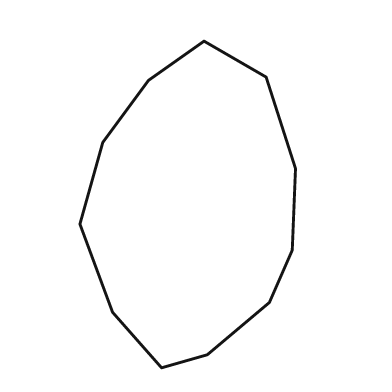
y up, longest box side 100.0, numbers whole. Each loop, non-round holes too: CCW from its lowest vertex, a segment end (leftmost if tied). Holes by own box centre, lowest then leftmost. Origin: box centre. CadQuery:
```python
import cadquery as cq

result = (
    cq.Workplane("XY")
    .moveTo(-8.0, -50.0)
    .lineTo(6.0, -46.0)
    .lineTo(25.0, -30.0)
    .lineTo(32.0, -14.0)
    .lineTo(33.0, 11.0)
    .lineTo(24.0, 39.0)
    .lineTo(5.0, 50.0)
    .lineTo(-12.0, 38.0)
    .lineTo(-26.0, 19.0)
    .lineTo(-33.0, -6.0)
    .lineTo(-23.0, -33.0)
    .close()
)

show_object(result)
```